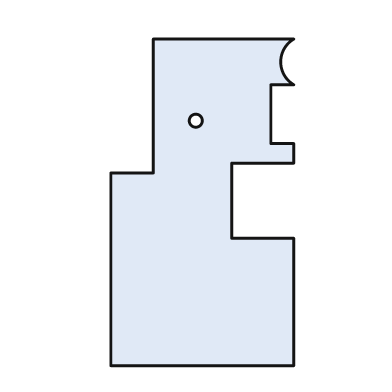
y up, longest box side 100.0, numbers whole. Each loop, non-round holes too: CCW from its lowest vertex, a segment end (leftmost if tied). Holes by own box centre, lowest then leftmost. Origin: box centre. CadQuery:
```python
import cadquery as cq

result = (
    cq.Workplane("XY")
    .moveTo(-28.0, -50.0)
    .lineTo(28.0, -50.0)
    .lineTo(28.0, -11.0)
    .lineTo(9.0, -11.0)
    .lineTo(9.0, 12.0)
    .lineTo(28.0, 12.0)
    .lineTo(28.0, 18.0)
    .lineTo(21.0, 18.0)
    .lineTo(21.0, 36.0)
    .lineTo(28.0, 36.0)
    .threePointArc((24.0, 43.0), (28.0, 50.0))
    .lineTo(-15.0, 50.0)
    .lineTo(-15.0, 9.0)
    .lineTo(-28.0, 9.0)
    .close()
    .moveTo(-2.0, 25.0)
    .circle(2.0)
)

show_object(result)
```